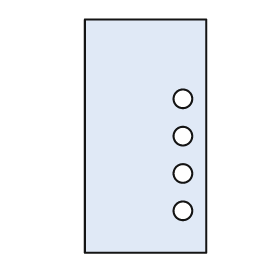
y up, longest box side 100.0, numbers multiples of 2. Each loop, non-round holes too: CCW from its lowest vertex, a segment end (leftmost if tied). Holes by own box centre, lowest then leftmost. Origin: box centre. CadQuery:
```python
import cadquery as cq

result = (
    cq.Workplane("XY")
    .moveTo(-26.0, -50.0)
    .lineTo(26.0, -50.0)
    .lineTo(26.0, 50.0)
    .lineTo(-26.0, 50.0)
    .close()
    .moveTo(16.0, -32.0)
    .circle(4.0)
    .moveTo(16.0, -16.0)
    .circle(4.0)
    .moveTo(16.0, 0.0)
    .circle(4.0)
    .moveTo(16.0, 16.0)
    .circle(4.0)
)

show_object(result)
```